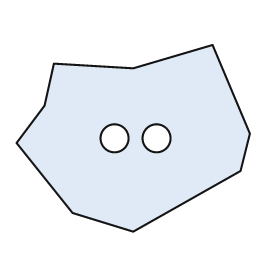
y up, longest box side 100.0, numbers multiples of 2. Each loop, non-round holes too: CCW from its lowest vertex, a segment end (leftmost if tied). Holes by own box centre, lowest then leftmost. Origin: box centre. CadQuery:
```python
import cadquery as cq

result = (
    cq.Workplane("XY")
    .moveTo(0.0, -40.0)
    .lineTo(46.0, -14.0)
    .lineTo(50.0, 2.0)
    .lineTo(34.0, 40.0)
    .lineTo(0.0, 30.0)
    .lineTo(-34.0, 32.0)
    .lineTo(-38.0, 14.0)
    .lineTo(-50.0, -2.0)
    .lineTo(-26.0, -32.0)
    .close()
    .moveTo(-8.0, 0.0)
    .circle(6.0)
    .moveTo(10.0, 0.0)
    .circle(6.0)
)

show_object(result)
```